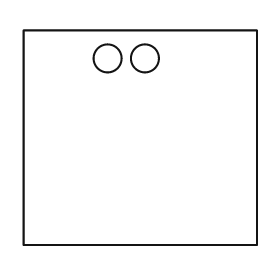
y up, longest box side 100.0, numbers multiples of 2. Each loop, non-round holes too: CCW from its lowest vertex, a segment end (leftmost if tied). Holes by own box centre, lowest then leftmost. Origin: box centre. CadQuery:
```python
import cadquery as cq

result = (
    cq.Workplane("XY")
    .moveTo(-50.0, -46.0)
    .lineTo(50.0, -46.0)
    .lineTo(50.0, 46.0)
    .lineTo(-50.0, 46.0)
    .close()
    .moveTo(-14.0, 34.0)
    .circle(6.0)
    .moveTo(2.0, 34.0)
    .circle(6.0)
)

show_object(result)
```